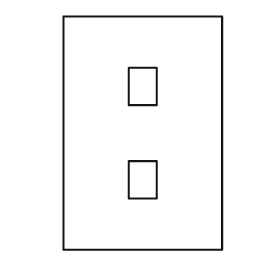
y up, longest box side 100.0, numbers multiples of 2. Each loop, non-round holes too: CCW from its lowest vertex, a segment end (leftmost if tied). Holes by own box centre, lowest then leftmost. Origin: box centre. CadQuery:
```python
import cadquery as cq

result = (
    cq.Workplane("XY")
    .moveTo(-34.0, -50.0)
    .lineTo(34.0, -50.0)
    .lineTo(34.0, 50.0)
    .lineTo(-34.0, 50.0)
    .close()
    .moveTo(-6.0, -28.0)
    .lineTo(6.0, -28.0)
    .lineTo(6.0, -12.0)
    .lineTo(-6.0, -12.0)
    .close()
    .moveTo(-6.0, 12.0)
    .lineTo(6.0, 12.0)
    .lineTo(6.0, 28.0)
    .lineTo(-6.0, 28.0)
    .close()
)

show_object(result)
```